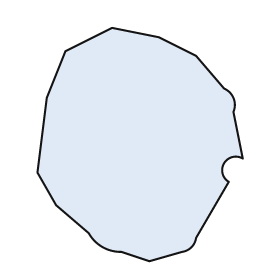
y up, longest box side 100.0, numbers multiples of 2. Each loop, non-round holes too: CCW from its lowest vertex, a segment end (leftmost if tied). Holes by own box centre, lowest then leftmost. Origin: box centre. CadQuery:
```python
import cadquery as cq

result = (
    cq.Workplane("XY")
    .moveTo(4.0, -50.0)
    .lineTo(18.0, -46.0)
    .threePointArc((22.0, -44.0), (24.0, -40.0))
    .lineTo(38.0, -16.0)
    .threePointArc((36.0, -8.0), (44.0, -6.0))
    .lineTo(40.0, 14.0)
    .threePointArc((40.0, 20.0), (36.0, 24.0))
    .lineTo(24.0, 38.0)
    .lineTo(8.0, 46.0)
    .lineTo(-12.0, 50.0)
    .lineTo(-32.0, 40.0)
    .lineTo(-40.0, 20.0)
    .lineTo(-44.0, -12.0)
    .lineTo(-36.0, -26.0)
    .lineTo(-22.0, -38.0)
    .threePointArc((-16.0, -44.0), (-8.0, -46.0))
    .close()
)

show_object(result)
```